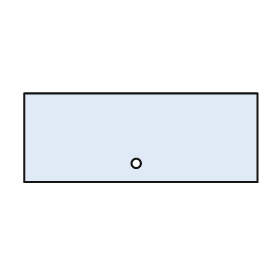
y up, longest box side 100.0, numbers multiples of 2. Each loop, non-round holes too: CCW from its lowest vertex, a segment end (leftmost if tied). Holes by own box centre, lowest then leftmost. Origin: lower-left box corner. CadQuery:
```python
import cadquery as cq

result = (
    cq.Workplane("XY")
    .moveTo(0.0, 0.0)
    .lineTo(100.0, 0.0)
    .lineTo(100.0, 38.0)
    .lineTo(0.0, 38.0)
    .close()
    .moveTo(48.0, 8.0)
    .circle(2.0)
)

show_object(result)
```